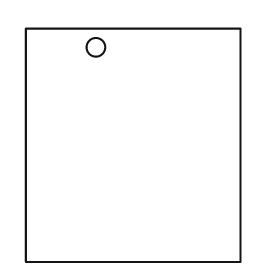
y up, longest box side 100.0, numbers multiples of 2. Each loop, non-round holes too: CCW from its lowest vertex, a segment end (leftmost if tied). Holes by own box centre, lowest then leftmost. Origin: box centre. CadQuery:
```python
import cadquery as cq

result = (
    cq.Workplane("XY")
    .moveTo(-46.0, -50.0)
    .lineTo(46.0, -50.0)
    .lineTo(46.0, 50.0)
    .lineTo(-46.0, 50.0)
    .close()
    .moveTo(-16.0, 42.0)
    .circle(4.0)
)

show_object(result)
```